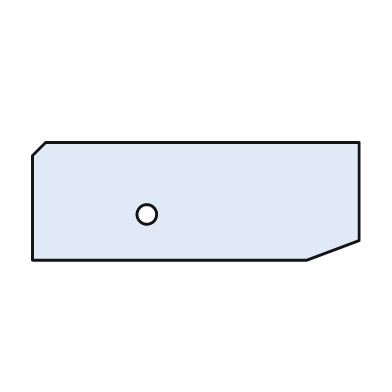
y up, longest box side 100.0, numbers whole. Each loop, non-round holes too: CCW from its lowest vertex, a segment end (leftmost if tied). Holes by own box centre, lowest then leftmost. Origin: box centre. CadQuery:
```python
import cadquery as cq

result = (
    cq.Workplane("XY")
    .moveTo(-50.0, -18.0)
    .lineTo(34.0, -18.0)
    .lineTo(50.0, -12.0)
    .lineTo(50.0, 18.0)
    .lineTo(-46.0, 18.0)
    .lineTo(-50.0, 14.0)
    .close()
    .moveTo(-15.0, -4.0)
    .circle(3.0)
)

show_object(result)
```